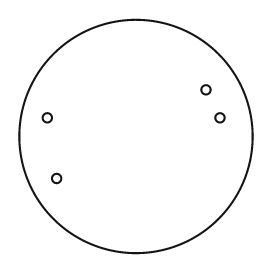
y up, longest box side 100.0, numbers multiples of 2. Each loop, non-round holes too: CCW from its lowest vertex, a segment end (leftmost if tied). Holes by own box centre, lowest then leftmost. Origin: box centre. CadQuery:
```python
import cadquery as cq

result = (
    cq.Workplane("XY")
    .moveTo(0.0, 0.0)
    .circle(50.0)
    .moveTo(-34.0, -18.0)
    .circle(2.0)
    .moveTo(-38.0, 8.0)
    .circle(2.0)
    .moveTo(36.0, 8.0)
    .circle(2.0)
    .moveTo(30.0, 20.0)
    .circle(2.0)
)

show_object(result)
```